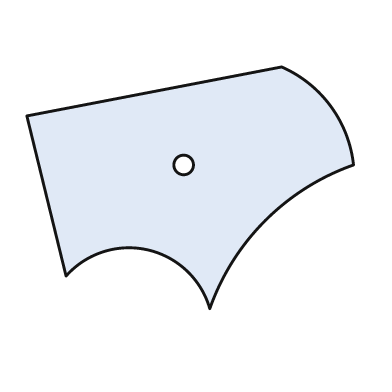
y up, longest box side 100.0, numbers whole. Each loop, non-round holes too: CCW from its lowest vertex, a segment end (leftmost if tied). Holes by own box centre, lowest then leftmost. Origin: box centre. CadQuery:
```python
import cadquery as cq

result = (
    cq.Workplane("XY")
    .moveTo(6.0, -37.0)
    .threePointArc((23.0, -10.0), (50.0, 7.0))
    .threePointArc((43.0, 25.0), (28.0, 37.0))
    .lineTo(-50.0, 22.0)
    .lineTo(-38.0, -27.0)
    .threePointArc((-13.0, -19.0), (6.0, -37.0))
    .close()
    .moveTo(-2.0, 7.0)
    .circle(3.0)
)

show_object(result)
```